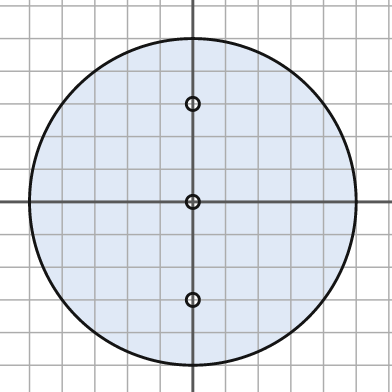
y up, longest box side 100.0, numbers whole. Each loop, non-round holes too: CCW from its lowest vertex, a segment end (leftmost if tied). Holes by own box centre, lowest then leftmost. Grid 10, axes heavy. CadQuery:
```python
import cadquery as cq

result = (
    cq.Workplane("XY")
    .moveTo(0.0, 0.0)
    .circle(50.0)
    .moveTo(0.0, -30.0)
    .circle(2.0)
    .moveTo(0.0, 0.0)
    .circle(2.0)
    .moveTo(0.0, 30.0)
    .circle(2.0)
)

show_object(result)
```